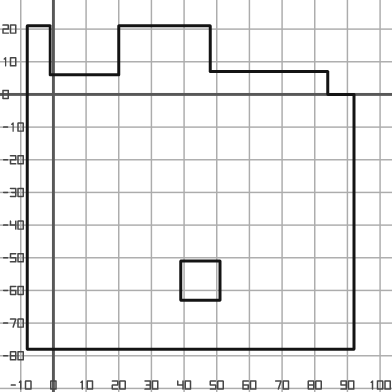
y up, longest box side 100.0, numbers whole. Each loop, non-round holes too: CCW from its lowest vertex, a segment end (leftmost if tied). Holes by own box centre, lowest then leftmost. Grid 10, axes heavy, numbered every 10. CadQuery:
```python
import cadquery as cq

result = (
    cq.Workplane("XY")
    .moveTo(-8.0, -78.0)
    .lineTo(92.0, -78.0)
    .lineTo(92.0, 0.0)
    .lineTo(84.0, 0.0)
    .lineTo(84.0, 7.0)
    .lineTo(48.0, 7.0)
    .lineTo(48.0, 21.0)
    .lineTo(20.0, 21.0)
    .lineTo(20.0, 6.0)
    .lineTo(-1.0, 6.0)
    .lineTo(-1.0, 21.0)
    .lineTo(-8.0, 21.0)
    .close()
    .moveTo(39.0, -63.0)
    .lineTo(51.0, -63.0)
    .lineTo(51.0, -51.0)
    .lineTo(39.0, -51.0)
    .close()
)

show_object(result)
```